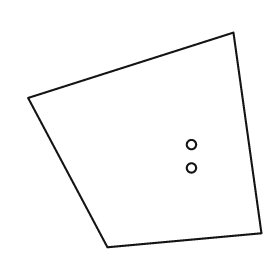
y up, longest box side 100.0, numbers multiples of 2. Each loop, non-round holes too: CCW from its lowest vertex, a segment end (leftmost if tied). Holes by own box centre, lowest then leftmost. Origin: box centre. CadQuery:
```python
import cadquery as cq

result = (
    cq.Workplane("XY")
    .moveTo(-16.0, -46.0)
    .lineTo(50.0, -40.0)
    .lineTo(38.0, 46.0)
    .lineTo(-50.0, 18.0)
    .close()
    .moveTo(20.0, -12.0)
    .circle(2.0)
    .moveTo(20.0, -2.0)
    .circle(2.0)
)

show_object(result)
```